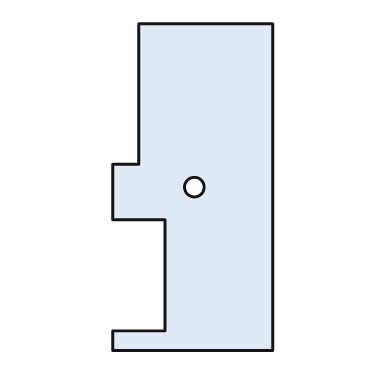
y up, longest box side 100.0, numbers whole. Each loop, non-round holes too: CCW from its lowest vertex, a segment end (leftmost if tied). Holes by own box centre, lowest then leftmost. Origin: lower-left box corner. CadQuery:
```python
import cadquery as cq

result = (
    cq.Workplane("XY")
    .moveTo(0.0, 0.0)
    .lineTo(49.0, 0.0)
    .lineTo(49.0, 100.0)
    .lineTo(8.0, 100.0)
    .lineTo(8.0, 57.0)
    .lineTo(0.0, 57.0)
    .lineTo(0.0, 40.0)
    .lineTo(16.0, 40.0)
    .lineTo(16.0, 6.0)
    .lineTo(0.0, 6.0)
    .close()
    .moveTo(25.0, 50.0)
    .circle(3.0)
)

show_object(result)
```